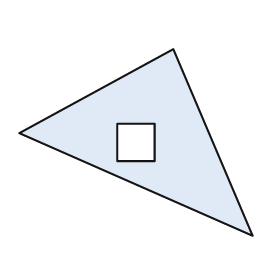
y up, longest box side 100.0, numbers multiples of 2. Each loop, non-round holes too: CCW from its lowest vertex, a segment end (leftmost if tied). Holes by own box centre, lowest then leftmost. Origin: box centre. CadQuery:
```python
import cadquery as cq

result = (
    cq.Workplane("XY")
    .moveTo(50.0, -40.0)
    .lineTo(16.0, 40.0)
    .lineTo(-50.0, 4.0)
    .close()
    .moveTo(-8.0, -8.0)
    .lineTo(8.0, -8.0)
    .lineTo(8.0, 8.0)
    .lineTo(-8.0, 8.0)
    .close()
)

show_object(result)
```